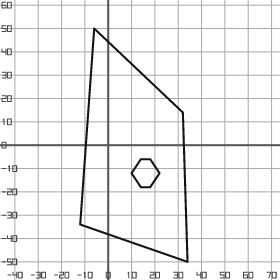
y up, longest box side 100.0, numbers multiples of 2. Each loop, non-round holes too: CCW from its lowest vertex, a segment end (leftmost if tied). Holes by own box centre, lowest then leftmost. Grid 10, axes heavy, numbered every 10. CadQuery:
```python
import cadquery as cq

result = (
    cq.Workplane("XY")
    .moveTo(34.0, -50.0)
    .lineTo(32.0, 14.0)
    .lineTo(-6.0, 50.0)
    .lineTo(-12.0, -34.0)
    .close()
    .moveTo(14.0, -18.0)
    .lineTo(18.0, -18.0)
    .lineTo(22.0, -12.0)
    .lineTo(18.0, -6.0)
    .lineTo(14.0, -6.0)
    .lineTo(10.0, -12.0)
    .close()
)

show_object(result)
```